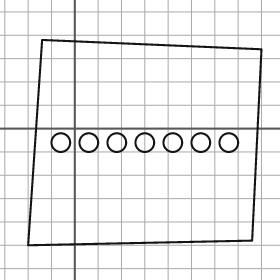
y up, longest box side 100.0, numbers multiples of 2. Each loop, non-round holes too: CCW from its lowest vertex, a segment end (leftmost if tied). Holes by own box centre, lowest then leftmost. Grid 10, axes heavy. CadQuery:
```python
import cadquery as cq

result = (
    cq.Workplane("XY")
    .moveTo(-20.0, -50.0)
    .lineTo(76.0, -48.0)
    .lineTo(80.0, 34.0)
    .lineTo(-14.0, 38.0)
    .close()
    .moveTo(-6.0, -6.0)
    .circle(4.0)
    .moveTo(6.0, -6.0)
    .circle(4.0)
    .moveTo(18.0, -6.0)
    .circle(4.0)
    .moveTo(30.0, -6.0)
    .circle(4.0)
    .moveTo(42.0, -6.0)
    .circle(4.0)
    .moveTo(54.0, -6.0)
    .circle(4.0)
    .moveTo(66.0, -6.0)
    .circle(4.0)
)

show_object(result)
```